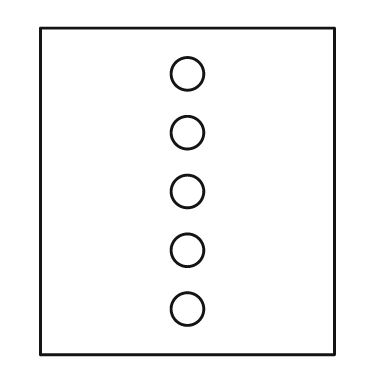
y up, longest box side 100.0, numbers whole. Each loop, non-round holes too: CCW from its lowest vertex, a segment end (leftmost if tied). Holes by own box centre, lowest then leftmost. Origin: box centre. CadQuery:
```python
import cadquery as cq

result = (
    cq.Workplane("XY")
    .moveTo(-45.0, -50.0)
    .lineTo(45.0, -50.0)
    .lineTo(45.0, 50.0)
    .lineTo(-45.0, 50.0)
    .close()
    .moveTo(0.0, -36.0)
    .circle(5.0)
    .moveTo(0.0, -18.0)
    .circle(5.0)
    .moveTo(0.0, 0.0)
    .circle(5.0)
    .moveTo(0.0, 18.0)
    .circle(5.0)
    .moveTo(0.0, 36.0)
    .circle(5.0)
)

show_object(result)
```